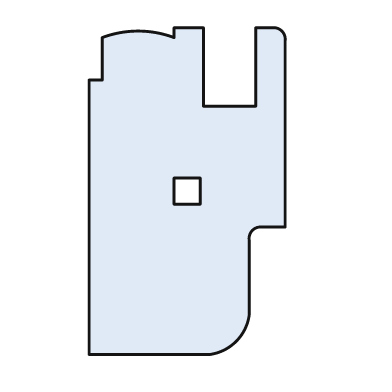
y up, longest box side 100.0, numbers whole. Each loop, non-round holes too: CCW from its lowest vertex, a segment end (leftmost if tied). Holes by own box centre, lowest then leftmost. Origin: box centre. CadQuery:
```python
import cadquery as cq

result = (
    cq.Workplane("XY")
    .moveTo(-30.0, -50.0)
    .lineTo(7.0, -50.0)
    .threePointArc((15.0, -46.0), (19.0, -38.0))
    .lineTo(19.0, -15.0)
    .threePointArc((20.0, -12.0), (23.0, -11.0))
    .lineTo(30.0, -11.0)
    .lineTo(30.0, 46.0)
    .threePointArc((29.0, 49.0), (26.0, 50.0))
    .lineTo(21.0, 50.0)
    .lineTo(21.0, 26.0)
    .lineTo(5.0, 26.0)
    .lineTo(5.0, 50.0)
    .lineTo(-4.0, 50.0)
    .lineTo(-4.0, 47.0)
    .threePointArc((-15.0, 49.0), (-26.0, 47.0))
    .lineTo(-26.0, 34.0)
    .lineTo(-30.0, 34.0)
    .close()
    .moveTo(-4.0, -4.0)
    .lineTo(4.0, -4.0)
    .lineTo(4.0, 4.0)
    .lineTo(-4.0, 4.0)
    .close()
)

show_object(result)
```